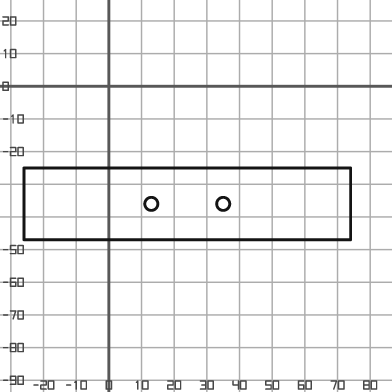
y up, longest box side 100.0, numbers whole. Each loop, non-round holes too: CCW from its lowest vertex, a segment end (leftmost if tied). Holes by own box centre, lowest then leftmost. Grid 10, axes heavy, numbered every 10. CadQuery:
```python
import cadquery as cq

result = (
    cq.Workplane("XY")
    .moveTo(-26.0, -47.0)
    .lineTo(74.0, -47.0)
    .lineTo(74.0, -25.0)
    .lineTo(-26.0, -25.0)
    .close()
    .moveTo(13.0, -36.0)
    .circle(2.0)
    .moveTo(35.0, -36.0)
    .circle(2.0)
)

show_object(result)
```